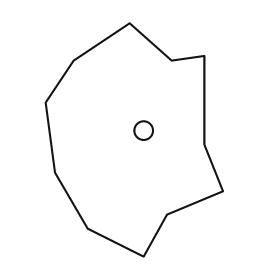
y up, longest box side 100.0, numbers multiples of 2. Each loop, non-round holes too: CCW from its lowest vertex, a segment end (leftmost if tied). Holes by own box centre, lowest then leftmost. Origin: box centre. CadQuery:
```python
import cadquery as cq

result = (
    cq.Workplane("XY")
    .moveTo(4.0, -50.0)
    .lineTo(14.0, -32.0)
    .lineTo(38.0, -22.0)
    .lineTo(30.0, -2.0)
    .lineTo(30.0, 36.0)
    .lineTo(16.0, 34.0)
    .lineTo(-2.0, 50.0)
    .lineTo(-26.0, 34.0)
    .lineTo(-38.0, 16.0)
    .lineTo(-34.0, -14.0)
    .lineTo(-20.0, -38.0)
    .close()
    .moveTo(4.0, 4.0)
    .circle(4.0)
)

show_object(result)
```